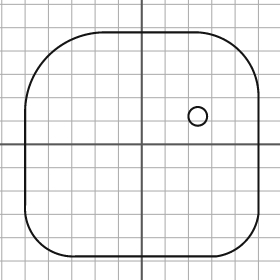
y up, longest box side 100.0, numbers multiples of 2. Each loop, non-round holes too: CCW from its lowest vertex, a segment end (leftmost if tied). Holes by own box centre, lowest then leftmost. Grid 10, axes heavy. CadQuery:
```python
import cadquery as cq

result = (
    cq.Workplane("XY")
    .moveTo(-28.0, -48.0)
    .lineTo(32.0, -48.0)
    .threePointArc((44.0, -42.0), (50.0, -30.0))
    .lineTo(50.0, 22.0)
    .threePointArc((42.0, 40.0), (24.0, 48.0))
    .lineTo(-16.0, 48.0)
    .threePointArc((-40.0, 38.0), (-50.0, 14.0))
    .lineTo(-50.0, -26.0)
    .threePointArc((-44.0, -42.0), (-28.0, -48.0))
    .close()
    .moveTo(24.0, 12.0)
    .circle(4.0)
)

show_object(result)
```